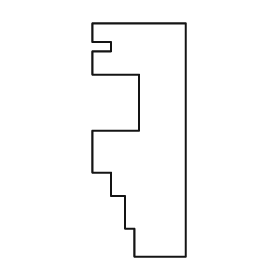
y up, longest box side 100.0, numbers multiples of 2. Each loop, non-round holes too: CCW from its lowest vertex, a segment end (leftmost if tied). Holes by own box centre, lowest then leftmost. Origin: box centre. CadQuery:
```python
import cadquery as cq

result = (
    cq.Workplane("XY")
    .moveTo(-2.0, -50.0)
    .lineTo(20.0, -50.0)
    .lineTo(20.0, 50.0)
    .lineTo(-20.0, 50.0)
    .lineTo(-20.0, 42.0)
    .lineTo(-12.0, 42.0)
    .lineTo(-12.0, 38.0)
    .lineTo(-20.0, 38.0)
    .lineTo(-20.0, 28.0)
    .lineTo(0.0, 28.0)
    .lineTo(0.0, 4.0)
    .lineTo(-20.0, 4.0)
    .lineTo(-20.0, -14.0)
    .lineTo(-12.0, -14.0)
    .lineTo(-12.0, -24.0)
    .lineTo(-6.0, -24.0)
    .lineTo(-6.0, -38.0)
    .lineTo(-2.0, -38.0)
    .close()
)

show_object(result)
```